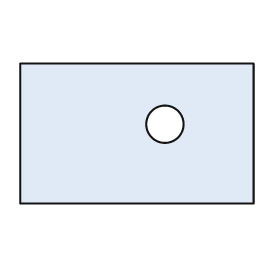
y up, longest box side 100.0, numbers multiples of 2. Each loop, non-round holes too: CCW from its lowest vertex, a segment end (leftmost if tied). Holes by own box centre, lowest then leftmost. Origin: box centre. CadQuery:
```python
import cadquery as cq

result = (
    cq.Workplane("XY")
    .moveTo(-50.0, -30.0)
    .lineTo(50.0, -30.0)
    .lineTo(50.0, 30.0)
    .lineTo(-50.0, 30.0)
    .close()
    .moveTo(12.0, 4.0)
    .circle(8.0)
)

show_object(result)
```